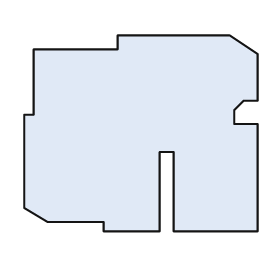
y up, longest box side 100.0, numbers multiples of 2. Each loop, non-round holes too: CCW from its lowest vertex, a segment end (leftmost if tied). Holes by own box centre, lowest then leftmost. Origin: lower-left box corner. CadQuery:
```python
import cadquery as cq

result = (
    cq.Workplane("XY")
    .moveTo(34.0, 0.0)
    .lineTo(58.0, 0.0)
    .lineTo(58.0, 34.0)
    .lineTo(64.0, 34.0)
    .lineTo(64.0, 0.0)
    .lineTo(100.0, 0.0)
    .lineTo(100.0, 46.0)
    .lineTo(90.0, 46.0)
    .lineTo(90.0, 52.0)
    .lineTo(94.0, 56.0)
    .lineTo(100.0, 56.0)
    .lineTo(100.0, 76.0)
    .lineTo(88.0, 84.0)
    .lineTo(40.0, 84.0)
    .lineTo(40.0, 78.0)
    .lineTo(4.0, 78.0)
    .lineTo(4.0, 50.0)
    .lineTo(0.0, 50.0)
    .lineTo(0.0, 10.0)
    .lineTo(10.0, 4.0)
    .lineTo(34.0, 4.0)
    .close()
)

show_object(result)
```